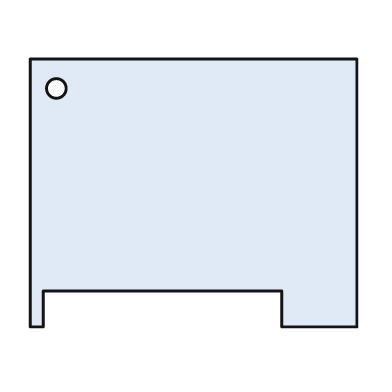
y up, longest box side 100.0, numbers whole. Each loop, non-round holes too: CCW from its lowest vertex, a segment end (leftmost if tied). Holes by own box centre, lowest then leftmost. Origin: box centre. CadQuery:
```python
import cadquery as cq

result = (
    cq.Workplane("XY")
    .moveTo(-50.0, -41.0)
    .lineTo(-46.0, -41.0)
    .lineTo(-46.0, -30.0)
    .lineTo(27.0, -30.0)
    .lineTo(27.0, -41.0)
    .lineTo(50.0, -41.0)
    .lineTo(50.0, 41.0)
    .lineTo(-50.0, 41.0)
    .close()
    .moveTo(-42.0, 32.0)
    .circle(3.0)
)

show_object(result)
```